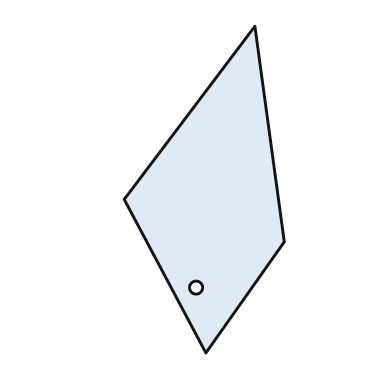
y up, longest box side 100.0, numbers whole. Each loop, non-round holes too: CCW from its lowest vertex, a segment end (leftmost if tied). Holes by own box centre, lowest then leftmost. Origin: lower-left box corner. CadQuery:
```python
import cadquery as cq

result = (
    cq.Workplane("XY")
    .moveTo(25.0, 0.0)
    .lineTo(49.0, 34.0)
    .lineTo(40.0, 100.0)
    .lineTo(0.0, 47.0)
    .close()
    .moveTo(22.0, 20.0)
    .circle(2.0)
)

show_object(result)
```